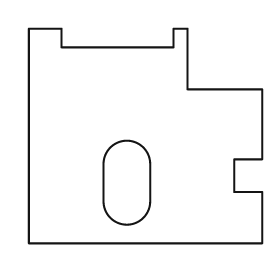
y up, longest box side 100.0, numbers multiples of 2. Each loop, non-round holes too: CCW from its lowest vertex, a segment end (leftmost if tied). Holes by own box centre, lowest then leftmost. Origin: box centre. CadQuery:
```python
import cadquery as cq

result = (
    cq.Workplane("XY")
    .moveTo(-50.0, -46.0)
    .lineTo(50.0, -46.0)
    .lineTo(50.0, -24.0)
    .lineTo(38.0, -24.0)
    .lineTo(38.0, -10.0)
    .lineTo(50.0, -10.0)
    .lineTo(50.0, 20.0)
    .lineTo(18.0, 20.0)
    .lineTo(18.0, 46.0)
    .lineTo(12.0, 46.0)
    .lineTo(12.0, 38.0)
    .lineTo(-36.0, 38.0)
    .lineTo(-36.0, 46.0)
    .lineTo(-50.0, 46.0)
    .close()
    .moveTo(-18.0, -28.0)
    .threePointArc((-8.0, -38.0), (2.0, -28.0))
    .lineTo(2.0, -12.0)
    .threePointArc((-8.0, -2.0), (-18.0, -12.0))
    .close()
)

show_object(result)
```